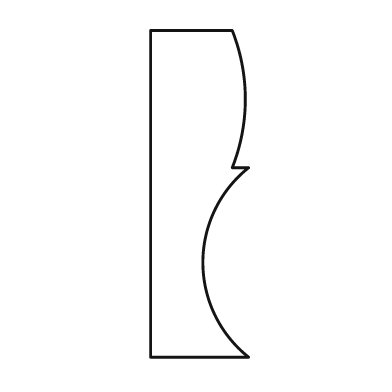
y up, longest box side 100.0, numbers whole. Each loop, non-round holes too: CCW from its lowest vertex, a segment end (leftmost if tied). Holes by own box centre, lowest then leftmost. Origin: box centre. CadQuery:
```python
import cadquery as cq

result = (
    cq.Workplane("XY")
    .moveTo(-15.0, -50.0)
    .lineTo(15.0, -50.0)
    .threePointArc((1.0, -21.0), (15.0, 8.0))
    .lineTo(10.0, 8.0)
    .threePointArc((14.0, 29.0), (10.0, 50.0))
    .lineTo(-15.0, 50.0)
    .close()
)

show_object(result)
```